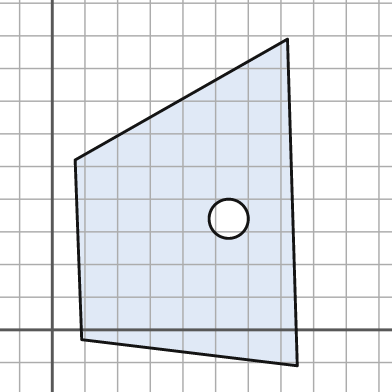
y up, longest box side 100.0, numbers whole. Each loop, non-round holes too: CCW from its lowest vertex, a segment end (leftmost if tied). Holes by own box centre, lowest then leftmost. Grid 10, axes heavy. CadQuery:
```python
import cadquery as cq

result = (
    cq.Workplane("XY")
    .moveTo(75.0, -11.0)
    .lineTo(72.0, 89.0)
    .lineTo(7.0, 52.0)
    .lineTo(9.0, -3.0)
    .close()
    .moveTo(54.0, 34.0)
    .circle(6.0)
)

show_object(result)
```